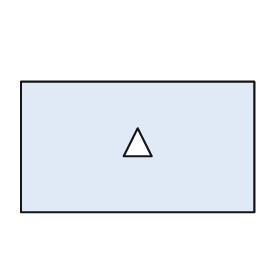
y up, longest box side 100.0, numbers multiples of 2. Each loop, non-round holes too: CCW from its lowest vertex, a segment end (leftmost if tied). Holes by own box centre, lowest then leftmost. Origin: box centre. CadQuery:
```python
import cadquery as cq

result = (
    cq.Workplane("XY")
    .moveTo(-50.0, -28.0)
    .lineTo(50.0, -28.0)
    .lineTo(50.0, 28.0)
    .lineTo(-50.0, 28.0)
    .close()
    .moveTo(-6.0, -4.0)
    .lineTo(6.0, -4.0)
    .lineTo(0.0, 8.0)
    .close()
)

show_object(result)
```